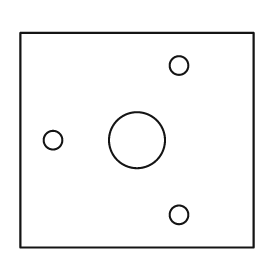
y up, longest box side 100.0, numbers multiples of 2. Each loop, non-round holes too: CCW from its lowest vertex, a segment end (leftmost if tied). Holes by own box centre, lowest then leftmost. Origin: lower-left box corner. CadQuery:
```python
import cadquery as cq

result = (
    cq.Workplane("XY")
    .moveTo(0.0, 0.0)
    .lineTo(100.0, 0.0)
    .lineTo(100.0, 92.0)
    .lineTo(0.0, 92.0)
    .close()
    .moveTo(68.0, 14.0)
    .circle(4.0)
    .moveTo(14.0, 46.0)
    .circle(4.0)
    .moveTo(50.0, 46.0)
    .circle(12.0)
    .moveTo(68.0, 78.0)
    .circle(4.0)
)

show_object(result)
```